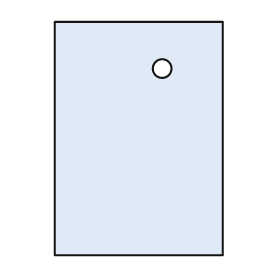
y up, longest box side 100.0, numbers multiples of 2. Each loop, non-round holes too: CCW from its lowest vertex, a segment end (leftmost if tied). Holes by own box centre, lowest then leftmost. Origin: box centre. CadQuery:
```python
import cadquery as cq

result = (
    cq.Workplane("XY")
    .moveTo(-36.0, -50.0)
    .lineTo(36.0, -50.0)
    .lineTo(36.0, 50.0)
    .lineTo(-36.0, 50.0)
    .close()
    .moveTo(10.0, 30.0)
    .circle(4.0)
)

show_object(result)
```